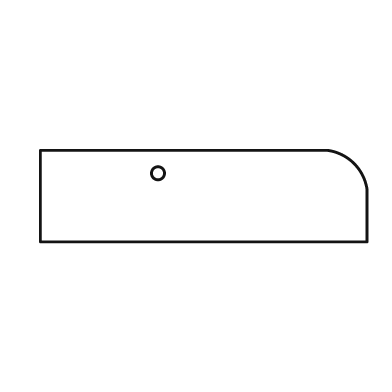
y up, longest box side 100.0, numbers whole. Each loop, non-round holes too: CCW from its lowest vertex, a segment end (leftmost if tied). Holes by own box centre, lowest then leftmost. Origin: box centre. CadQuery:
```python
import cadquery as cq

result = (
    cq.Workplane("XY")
    .moveTo(-50.0, -14.0)
    .lineTo(50.0, -14.0)
    .lineTo(50.0, 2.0)
    .threePointArc((46.0, 10.0), (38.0, 14.0))
    .lineTo(-50.0, 14.0)
    .close()
    .moveTo(-14.0, 7.0)
    .circle(2.0)
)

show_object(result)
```